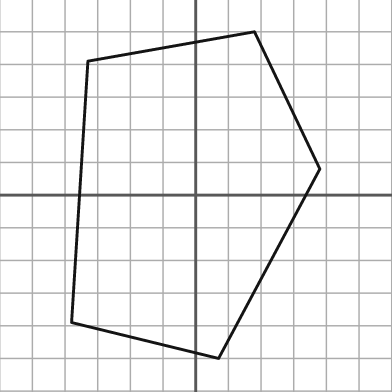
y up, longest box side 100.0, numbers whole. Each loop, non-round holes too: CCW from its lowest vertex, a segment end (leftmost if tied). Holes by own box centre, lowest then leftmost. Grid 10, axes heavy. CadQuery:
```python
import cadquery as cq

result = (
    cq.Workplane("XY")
    .moveTo(7.0, -50.0)
    .lineTo(38.0, 8.0)
    .lineTo(18.0, 50.0)
    .lineTo(-33.0, 41.0)
    .lineTo(-38.0, -39.0)
    .close()
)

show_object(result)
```